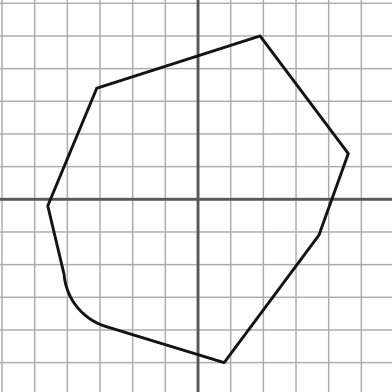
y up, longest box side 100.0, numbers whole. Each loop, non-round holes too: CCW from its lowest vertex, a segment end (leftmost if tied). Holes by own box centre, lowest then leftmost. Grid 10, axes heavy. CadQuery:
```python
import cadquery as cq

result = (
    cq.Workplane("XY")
    .moveTo(8.0, -50.0)
    .lineTo(37.0, -11.0)
    .lineTo(46.0, 14.0)
    .lineTo(19.0, 50.0)
    .lineTo(-31.0, 34.0)
    .lineTo(-46.0, -2.0)
    .lineTo(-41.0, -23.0)
    .threePointArc((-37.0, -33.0), (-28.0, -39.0))
    .close()
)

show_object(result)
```